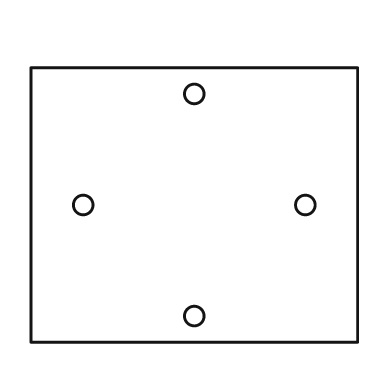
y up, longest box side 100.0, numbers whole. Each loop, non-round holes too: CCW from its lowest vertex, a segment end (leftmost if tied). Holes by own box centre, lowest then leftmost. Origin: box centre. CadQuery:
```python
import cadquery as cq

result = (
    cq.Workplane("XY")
    .moveTo(-50.0, -42.0)
    .lineTo(50.0, -42.0)
    .lineTo(50.0, 42.0)
    .lineTo(-50.0, 42.0)
    .close()
    .moveTo(0.0, -34.0)
    .circle(3.0)
    .moveTo(-34.0, 0.0)
    .circle(3.0)
    .moveTo(34.0, 0.0)
    .circle(3.0)
    .moveTo(0.0, 34.0)
    .circle(3.0)
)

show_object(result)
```